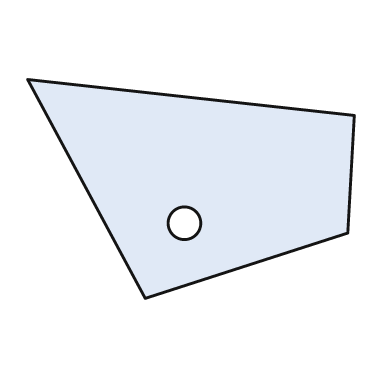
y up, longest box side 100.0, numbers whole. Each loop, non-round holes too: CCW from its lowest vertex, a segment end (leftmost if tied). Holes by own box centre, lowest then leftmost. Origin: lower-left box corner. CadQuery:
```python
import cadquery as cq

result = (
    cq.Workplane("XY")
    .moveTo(36.0, 0.0)
    .lineTo(98.0, 20.0)
    .lineTo(100.0, 56.0)
    .lineTo(0.0, 67.0)
    .close()
    .moveTo(48.0, 23.0)
    .circle(5.0)
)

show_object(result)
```